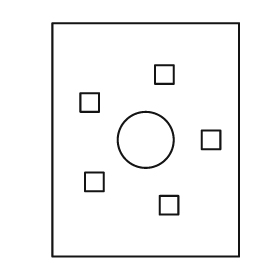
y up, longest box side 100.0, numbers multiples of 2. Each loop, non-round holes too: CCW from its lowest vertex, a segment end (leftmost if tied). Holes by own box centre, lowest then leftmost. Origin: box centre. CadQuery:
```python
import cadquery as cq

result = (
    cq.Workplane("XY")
    .moveTo(-40.0, -50.0)
    .lineTo(40.0, -50.0)
    .lineTo(40.0, 50.0)
    .lineTo(-40.0, 50.0)
    .close()
    .moveTo(6.0, -32.0)
    .lineTo(14.0, -32.0)
    .lineTo(14.0, -24.0)
    .lineTo(6.0, -24.0)
    .close()
    .moveTo(-26.0, -22.0)
    .lineTo(-18.0, -22.0)
    .lineTo(-18.0, -14.0)
    .lineTo(-26.0, -14.0)
    .close()
    .moveTo(0.0, 0.0)
    .circle(12.0)
    .moveTo(24.0, -4.0)
    .lineTo(32.0, -4.0)
    .lineTo(32.0, 4.0)
    .lineTo(24.0, 4.0)
    .close()
    .moveTo(-28.0, 12.0)
    .lineTo(-20.0, 12.0)
    .lineTo(-20.0, 20.0)
    .lineTo(-28.0, 20.0)
    .close()
    .moveTo(4.0, 24.0)
    .lineTo(12.0, 24.0)
    .lineTo(12.0, 32.0)
    .lineTo(4.0, 32.0)
    .close()
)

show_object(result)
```